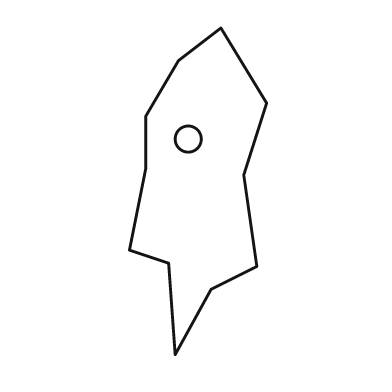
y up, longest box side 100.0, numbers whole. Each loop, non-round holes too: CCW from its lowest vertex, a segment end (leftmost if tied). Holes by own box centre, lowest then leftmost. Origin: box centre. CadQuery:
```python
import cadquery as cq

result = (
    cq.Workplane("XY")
    .moveTo(-7.0, -50.0)
    .lineTo(4.0, -30.0)
    .lineTo(18.0, -23.0)
    .lineTo(14.0, 5.0)
    .lineTo(21.0, 27.0)
    .lineTo(7.0, 50.0)
    .lineTo(-6.0, 40.0)
    .lineTo(-16.0, 23.0)
    .lineTo(-16.0, 7.0)
    .lineTo(-21.0, -18.0)
    .lineTo(-9.0, -22.0)
    .close()
    .moveTo(-3.0, 16.0)
    .circle(4.0)
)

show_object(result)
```